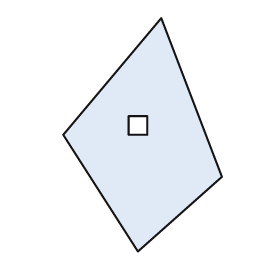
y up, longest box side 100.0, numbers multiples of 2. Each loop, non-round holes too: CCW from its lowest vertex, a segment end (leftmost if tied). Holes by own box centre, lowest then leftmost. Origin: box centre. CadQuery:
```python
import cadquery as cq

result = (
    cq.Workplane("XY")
    .moveTo(-2.0, -50.0)
    .lineTo(34.0, -18.0)
    .lineTo(8.0, 50.0)
    .lineTo(-34.0, 0.0)
    .close()
    .moveTo(-6.0, 0.0)
    .lineTo(2.0, 0.0)
    .lineTo(2.0, 8.0)
    .lineTo(-6.0, 8.0)
    .close()
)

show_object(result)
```